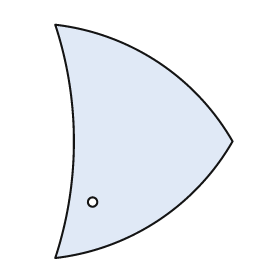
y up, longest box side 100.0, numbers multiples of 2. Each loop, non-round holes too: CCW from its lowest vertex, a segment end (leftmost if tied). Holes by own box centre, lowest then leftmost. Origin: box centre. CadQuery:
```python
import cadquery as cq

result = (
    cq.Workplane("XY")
    .moveTo(-38.0, -50.0)
    .threePointArc((6.0, -34.0), (38.0, 0.0))
    .threePointArc((6.0, 34.0), (-38.0, 50.0))
    .threePointArc((-30.0, 0.0), (-38.0, -50.0))
    .close()
    .moveTo(-22.0, -26.0)
    .circle(2.0)
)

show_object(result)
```